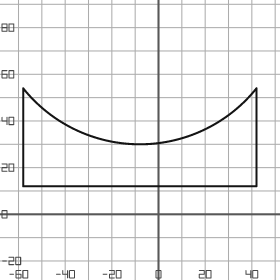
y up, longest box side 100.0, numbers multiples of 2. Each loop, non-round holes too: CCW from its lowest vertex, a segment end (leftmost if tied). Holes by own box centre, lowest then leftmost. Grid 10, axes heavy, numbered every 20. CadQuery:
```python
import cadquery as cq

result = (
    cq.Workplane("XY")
    .moveTo(-58.0, 12.0)
    .lineTo(42.0, 12.0)
    .lineTo(42.0, 54.0)
    .threePointArc((-8.0, 30.0), (-58.0, 54.0))
    .close()
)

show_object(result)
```